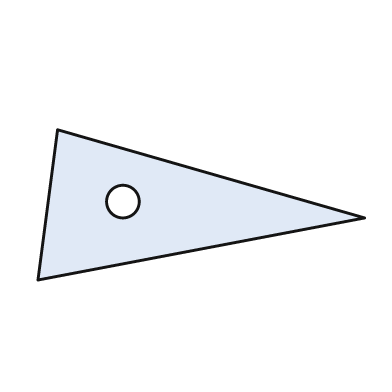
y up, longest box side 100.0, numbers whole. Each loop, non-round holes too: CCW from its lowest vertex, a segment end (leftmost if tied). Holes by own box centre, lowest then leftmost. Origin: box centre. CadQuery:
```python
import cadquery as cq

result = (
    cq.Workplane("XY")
    .moveTo(-50.0, -23.0)
    .lineTo(50.0, -4.0)
    .lineTo(-44.0, 23.0)
    .close()
    .moveTo(-24.0, 1.0)
    .circle(5.0)
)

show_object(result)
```